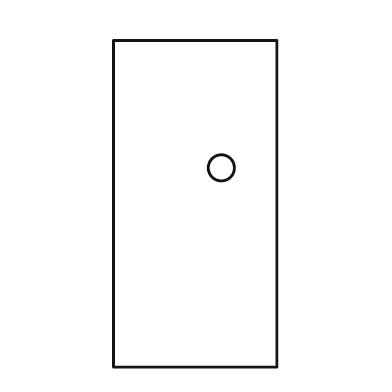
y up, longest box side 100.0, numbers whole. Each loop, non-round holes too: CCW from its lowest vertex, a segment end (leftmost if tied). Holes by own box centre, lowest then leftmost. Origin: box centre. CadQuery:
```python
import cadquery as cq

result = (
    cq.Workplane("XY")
    .moveTo(-25.0, -50.0)
    .lineTo(25.0, -50.0)
    .lineTo(25.0, 50.0)
    .lineTo(-25.0, 50.0)
    .close()
    .moveTo(8.0, 11.0)
    .circle(4.0)
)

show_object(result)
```